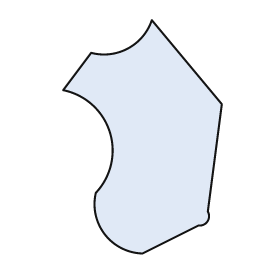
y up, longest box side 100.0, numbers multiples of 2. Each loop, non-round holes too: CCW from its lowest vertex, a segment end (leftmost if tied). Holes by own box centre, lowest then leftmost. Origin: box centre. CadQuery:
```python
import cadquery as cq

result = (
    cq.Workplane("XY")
    .moveTo(0.0, -50.0)
    .lineTo(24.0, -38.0)
    .threePointArc((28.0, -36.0), (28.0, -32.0))
    .lineTo(34.0, 14.0)
    .lineTo(4.0, 50.0)
    .threePointArc((-6.0, 38.0), (-22.0, 36.0))
    .lineTo(-34.0, 20.0)
    .threePointArc((-14.0, 2.0), (-20.0, -24.0))
    .threePointArc((-16.0, -42.0), (0.0, -50.0))
    .close()
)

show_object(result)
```